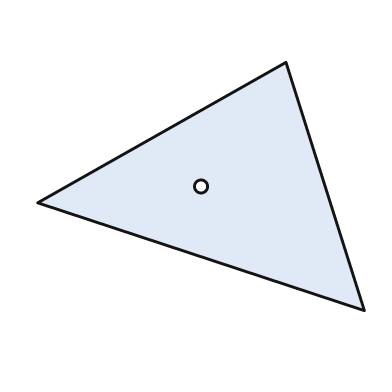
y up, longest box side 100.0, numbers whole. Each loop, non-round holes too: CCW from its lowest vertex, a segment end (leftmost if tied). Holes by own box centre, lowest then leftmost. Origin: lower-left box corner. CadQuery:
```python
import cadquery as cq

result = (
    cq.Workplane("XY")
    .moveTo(100.0, 0.0)
    .lineTo(76.0, 76.0)
    .lineTo(0.0, 33.0)
    .close()
    .moveTo(50.0, 38.0)
    .circle(2.0)
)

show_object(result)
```